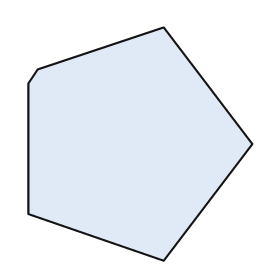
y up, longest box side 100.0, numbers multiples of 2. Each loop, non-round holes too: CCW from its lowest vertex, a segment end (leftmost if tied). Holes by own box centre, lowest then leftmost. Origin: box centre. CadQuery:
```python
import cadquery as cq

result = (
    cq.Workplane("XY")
    .moveTo(10.0, -50.0)
    .lineTo(48.0, 0.0)
    .lineTo(10.0, 50.0)
    .lineTo(-44.0, 32.0)
    .lineTo(-48.0, 26.0)
    .lineTo(-48.0, -30.0)
    .close()
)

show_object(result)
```